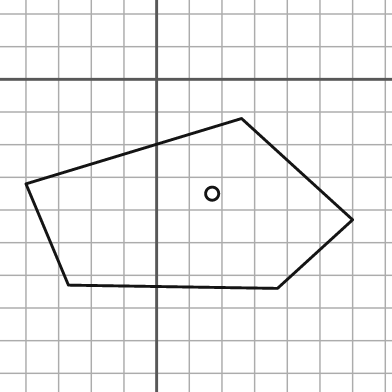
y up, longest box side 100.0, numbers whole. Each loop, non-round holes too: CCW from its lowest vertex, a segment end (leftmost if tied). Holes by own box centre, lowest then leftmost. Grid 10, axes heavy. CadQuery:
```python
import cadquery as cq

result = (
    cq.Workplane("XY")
    .moveTo(37.0, -64.0)
    .lineTo(60.0, -43.0)
    .lineTo(26.0, -12.0)
    .lineTo(-40.0, -32.0)
    .lineTo(-27.0, -63.0)
    .close()
    .moveTo(17.0, -35.0)
    .circle(2.0)
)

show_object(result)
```